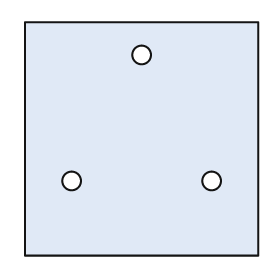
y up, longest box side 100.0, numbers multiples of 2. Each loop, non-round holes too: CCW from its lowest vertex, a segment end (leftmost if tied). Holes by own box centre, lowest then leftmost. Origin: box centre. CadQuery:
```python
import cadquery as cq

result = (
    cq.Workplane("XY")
    .moveTo(-50.0, -50.0)
    .lineTo(50.0, -50.0)
    .lineTo(50.0, 50.0)
    .lineTo(-50.0, 50.0)
    .close()
    .moveTo(-30.0, -18.0)
    .circle(4.0)
    .moveTo(30.0, -18.0)
    .circle(4.0)
    .moveTo(0.0, 36.0)
    .circle(4.0)
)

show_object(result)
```